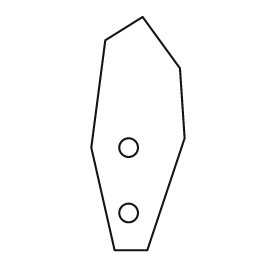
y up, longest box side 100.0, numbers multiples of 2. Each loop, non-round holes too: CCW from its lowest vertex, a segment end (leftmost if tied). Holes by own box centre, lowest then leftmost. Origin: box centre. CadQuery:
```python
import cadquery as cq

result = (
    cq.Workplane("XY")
    .moveTo(-10.0, -50.0)
    .lineTo(4.0, -50.0)
    .lineTo(20.0, -2.0)
    .lineTo(18.0, 28.0)
    .lineTo(2.0, 50.0)
    .lineTo(-14.0, 40.0)
    .lineTo(-20.0, -6.0)
    .close()
    .moveTo(-4.0, -34.0)
    .circle(4.0)
    .moveTo(-4.0, -6.0)
    .circle(4.0)
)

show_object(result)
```